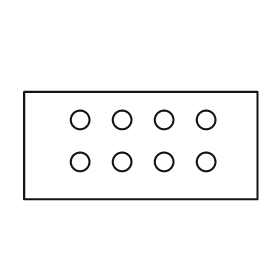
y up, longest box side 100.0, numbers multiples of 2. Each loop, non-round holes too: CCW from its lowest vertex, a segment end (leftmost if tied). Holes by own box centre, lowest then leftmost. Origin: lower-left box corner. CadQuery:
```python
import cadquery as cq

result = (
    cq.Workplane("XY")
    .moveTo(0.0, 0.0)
    .lineTo(100.0, 0.0)
    .lineTo(100.0, 46.0)
    .lineTo(0.0, 46.0)
    .close()
    .moveTo(24.0, 16.0)
    .circle(4.0)
    .moveTo(42.0, 16.0)
    .circle(4.0)
    .moveTo(60.0, 16.0)
    .circle(4.0)
    .moveTo(78.0, 16.0)
    .circle(4.0)
    .moveTo(24.0, 34.0)
    .circle(4.0)
    .moveTo(42.0, 34.0)
    .circle(4.0)
    .moveTo(60.0, 34.0)
    .circle(4.0)
    .moveTo(78.0, 34.0)
    .circle(4.0)
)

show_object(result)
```